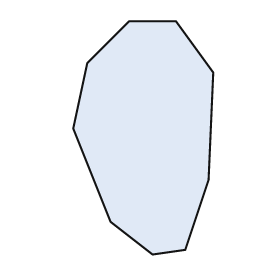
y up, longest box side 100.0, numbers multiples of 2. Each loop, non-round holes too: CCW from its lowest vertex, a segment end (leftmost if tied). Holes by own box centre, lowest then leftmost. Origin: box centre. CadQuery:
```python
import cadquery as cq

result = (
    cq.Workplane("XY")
    .moveTo(4.0, -50.0)
    .lineTo(18.0, -48.0)
    .lineTo(28.0, -18.0)
    .lineTo(30.0, 28.0)
    .lineTo(14.0, 50.0)
    .lineTo(-6.0, 50.0)
    .lineTo(-24.0, 32.0)
    .lineTo(-30.0, 4.0)
    .lineTo(-14.0, -36.0)
    .close()
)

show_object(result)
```